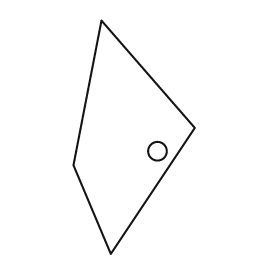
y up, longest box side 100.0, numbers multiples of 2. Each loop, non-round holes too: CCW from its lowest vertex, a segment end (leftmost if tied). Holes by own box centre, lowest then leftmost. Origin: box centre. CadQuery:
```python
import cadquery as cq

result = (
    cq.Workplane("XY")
    .moveTo(-10.0, -50.0)
    .lineTo(26.0, 4.0)
    .lineTo(-14.0, 50.0)
    .lineTo(-26.0, -12.0)
    .close()
    .moveTo(10.0, -6.0)
    .circle(4.0)
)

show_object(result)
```